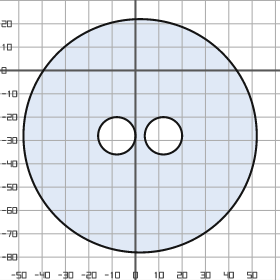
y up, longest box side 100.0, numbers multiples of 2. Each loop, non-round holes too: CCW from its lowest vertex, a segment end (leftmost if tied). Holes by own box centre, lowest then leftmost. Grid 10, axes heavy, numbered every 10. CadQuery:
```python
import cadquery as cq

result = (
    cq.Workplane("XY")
    .moveTo(2.0, -28.0)
    .circle(50.0)
    .moveTo(-8.0, -28.0)
    .circle(8.0)
    .moveTo(12.0, -28.0)
    .circle(8.0)
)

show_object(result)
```